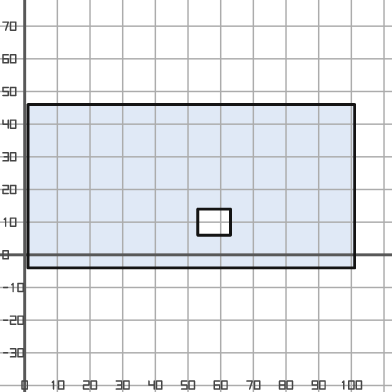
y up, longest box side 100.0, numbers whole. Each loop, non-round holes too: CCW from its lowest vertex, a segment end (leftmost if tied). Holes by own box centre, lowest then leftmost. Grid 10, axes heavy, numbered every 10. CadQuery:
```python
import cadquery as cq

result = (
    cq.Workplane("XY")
    .moveTo(1.0, -4.0)
    .lineTo(101.0, -4.0)
    .lineTo(101.0, 46.0)
    .lineTo(1.0, 46.0)
    .close()
    .moveTo(53.0, 6.0)
    .lineTo(63.0, 6.0)
    .lineTo(63.0, 14.0)
    .lineTo(53.0, 14.0)
    .close()
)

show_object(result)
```